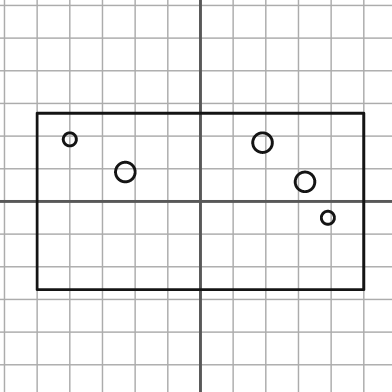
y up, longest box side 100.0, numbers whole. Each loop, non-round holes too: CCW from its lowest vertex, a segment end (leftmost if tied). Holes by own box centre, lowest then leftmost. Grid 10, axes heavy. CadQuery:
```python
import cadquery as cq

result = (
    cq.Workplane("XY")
    .moveTo(-50.0, -27.0)
    .lineTo(50.0, -27.0)
    .lineTo(50.0, 27.0)
    .lineTo(-50.0, 27.0)
    .close()
    .moveTo(39.0, -5.0)
    .circle(2.0)
    .moveTo(32.0, 6.0)
    .circle(3.0)
    .moveTo(-23.0, 9.0)
    .circle(3.0)
    .moveTo(19.0, 18.0)
    .circle(3.0)
    .moveTo(-40.0, 19.0)
    .circle(2.0)
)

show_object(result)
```